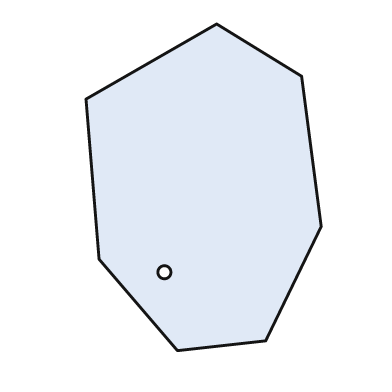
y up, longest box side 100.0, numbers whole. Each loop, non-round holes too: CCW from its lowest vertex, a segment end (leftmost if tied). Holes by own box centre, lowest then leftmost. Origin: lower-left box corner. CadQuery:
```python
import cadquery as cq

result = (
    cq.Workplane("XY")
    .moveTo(28.0, 0.0)
    .lineTo(55.0, 3.0)
    .lineTo(72.0, 38.0)
    .lineTo(66.0, 84.0)
    .lineTo(40.0, 100.0)
    .lineTo(0.0, 77.0)
    .lineTo(4.0, 28.0)
    .close()
    .moveTo(24.0, 24.0)
    .circle(2.0)
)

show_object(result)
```